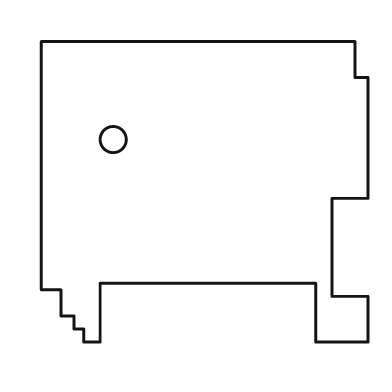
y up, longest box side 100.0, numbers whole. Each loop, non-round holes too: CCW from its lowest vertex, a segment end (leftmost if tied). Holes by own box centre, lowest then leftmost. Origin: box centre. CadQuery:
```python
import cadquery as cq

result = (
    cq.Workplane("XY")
    .moveTo(-37.0, -46.0)
    .lineTo(-32.0, -46.0)
    .lineTo(-32.0, -28.0)
    .lineTo(34.0, -28.0)
    .lineTo(34.0, -46.0)
    .lineTo(50.0, -46.0)
    .lineTo(50.0, -32.0)
    .lineTo(39.0, -32.0)
    .lineTo(39.0, -2.0)
    .lineTo(50.0, -2.0)
    .lineTo(50.0, 35.0)
    .lineTo(46.0, 35.0)
    .lineTo(46.0, 46.0)
    .lineTo(-50.0, 46.0)
    .lineTo(-50.0, -30.0)
    .lineTo(-44.0, -30.0)
    .lineTo(-44.0, -38.0)
    .lineTo(-40.0, -38.0)
    .lineTo(-40.0, -42.0)
    .lineTo(-37.0, -42.0)
    .close()
    .moveTo(-28.0, 16.0)
    .circle(4.0)
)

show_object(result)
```